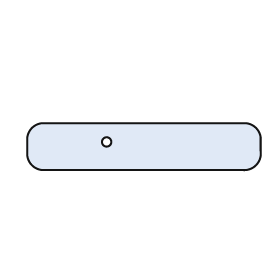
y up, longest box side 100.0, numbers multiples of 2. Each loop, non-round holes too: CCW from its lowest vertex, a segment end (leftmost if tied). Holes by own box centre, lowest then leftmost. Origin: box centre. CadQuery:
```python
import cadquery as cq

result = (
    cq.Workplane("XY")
    .moveTo(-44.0, -10.0)
    .lineTo(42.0, -10.0)
    .threePointArc((48.0, -8.0), (50.0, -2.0))
    .lineTo(50.0, 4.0)
    .threePointArc((48.0, 8.0), (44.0, 10.0))
    .lineTo(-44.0, 10.0)
    .threePointArc((-48.0, 8.0), (-50.0, 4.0))
    .lineTo(-50.0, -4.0)
    .threePointArc((-48.0, -8.0), (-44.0, -10.0))
    .close()
    .moveTo(-16.0, 2.0)
    .circle(2.0)
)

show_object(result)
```